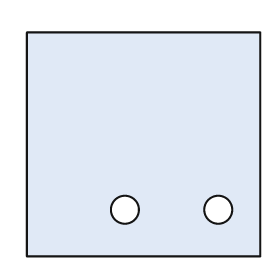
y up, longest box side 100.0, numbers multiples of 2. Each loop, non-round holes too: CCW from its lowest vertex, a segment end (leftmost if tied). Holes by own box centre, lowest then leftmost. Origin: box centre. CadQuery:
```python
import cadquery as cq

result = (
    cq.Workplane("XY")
    .moveTo(-50.0, -48.0)
    .lineTo(50.0, -48.0)
    .lineTo(50.0, 48.0)
    .lineTo(-50.0, 48.0)
    .close()
    .moveTo(-8.0, -28.0)
    .circle(6.0)
    .moveTo(32.0, -28.0)
    .circle(6.0)
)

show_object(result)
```